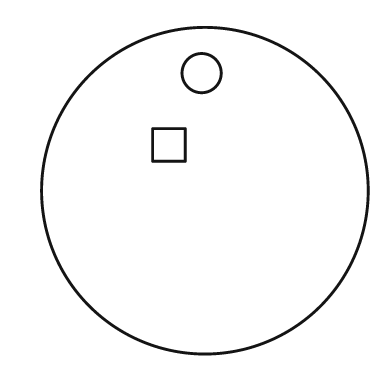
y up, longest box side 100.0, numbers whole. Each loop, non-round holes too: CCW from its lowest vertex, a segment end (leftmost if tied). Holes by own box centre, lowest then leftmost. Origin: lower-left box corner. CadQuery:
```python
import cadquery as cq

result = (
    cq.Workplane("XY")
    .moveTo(50.0, 50.0)
    .circle(50.0)
    .moveTo(34.0, 59.0)
    .lineTo(44.0, 59.0)
    .lineTo(44.0, 69.0)
    .lineTo(34.0, 69.0)
    .close()
    .moveTo(49.0, 86.0)
    .circle(6.0)
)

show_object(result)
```